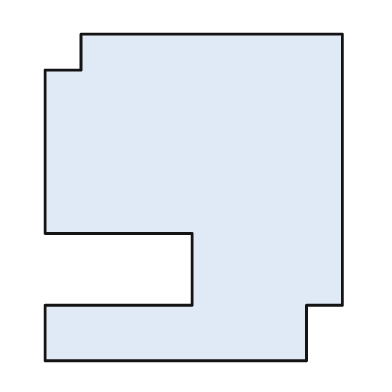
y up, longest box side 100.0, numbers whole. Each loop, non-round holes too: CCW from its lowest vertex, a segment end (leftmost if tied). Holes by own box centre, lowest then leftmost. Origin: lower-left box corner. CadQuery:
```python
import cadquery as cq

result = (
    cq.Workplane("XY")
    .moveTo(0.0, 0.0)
    .lineTo(80.0, 0.0)
    .lineTo(80.0, 17.0)
    .lineTo(91.0, 17.0)
    .lineTo(91.0, 100.0)
    .lineTo(11.0, 100.0)
    .lineTo(11.0, 89.0)
    .lineTo(0.0, 89.0)
    .lineTo(0.0, 39.0)
    .lineTo(45.0, 39.0)
    .lineTo(45.0, 17.0)
    .lineTo(0.0, 17.0)
    .close()
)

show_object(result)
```